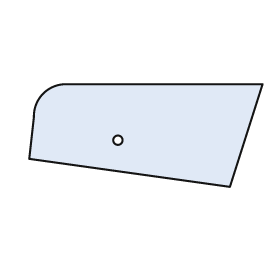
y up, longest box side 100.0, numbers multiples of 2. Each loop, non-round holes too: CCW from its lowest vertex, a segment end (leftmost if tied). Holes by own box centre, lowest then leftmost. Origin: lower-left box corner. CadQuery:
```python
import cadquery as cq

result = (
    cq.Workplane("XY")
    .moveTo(86.0, 0.0)
    .lineTo(100.0, 44.0)
    .lineTo(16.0, 44.0)
    .threePointArc((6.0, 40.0), (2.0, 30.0))
    .lineTo(0.0, 12.0)
    .close()
    .moveTo(38.0, 20.0)
    .circle(2.0)
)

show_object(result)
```